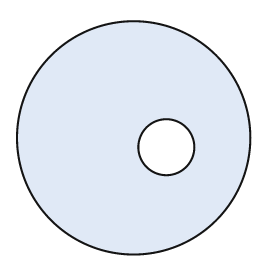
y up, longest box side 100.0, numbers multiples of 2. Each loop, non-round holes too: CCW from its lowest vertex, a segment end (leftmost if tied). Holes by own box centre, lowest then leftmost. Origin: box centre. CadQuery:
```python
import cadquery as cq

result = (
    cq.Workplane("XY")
    .moveTo(0.0, 0.0)
    .circle(50.0)
    .moveTo(14.0, -4.0)
    .circle(12.0)
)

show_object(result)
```